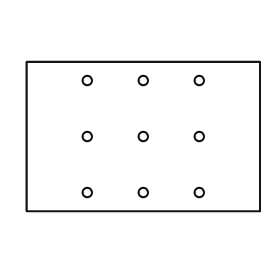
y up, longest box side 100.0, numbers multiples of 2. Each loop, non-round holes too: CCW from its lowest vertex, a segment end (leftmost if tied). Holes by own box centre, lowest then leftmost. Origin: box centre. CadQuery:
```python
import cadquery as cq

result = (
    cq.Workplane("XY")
    .moveTo(-50.0, -32.0)
    .lineTo(50.0, -32.0)
    .lineTo(50.0, 32.0)
    .lineTo(-50.0, 32.0)
    .close()
    .moveTo(-24.0, -24.0)
    .circle(2.0)
    .moveTo(0.0, -24.0)
    .circle(2.0)
    .moveTo(24.0, -24.0)
    .circle(2.0)
    .moveTo(-24.0, 0.0)
    .circle(2.0)
    .moveTo(0.0, 0.0)
    .circle(2.0)
    .moveTo(24.0, 0.0)
    .circle(2.0)
    .moveTo(-24.0, 24.0)
    .circle(2.0)
    .moveTo(0.0, 24.0)
    .circle(2.0)
    .moveTo(24.0, 24.0)
    .circle(2.0)
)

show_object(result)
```